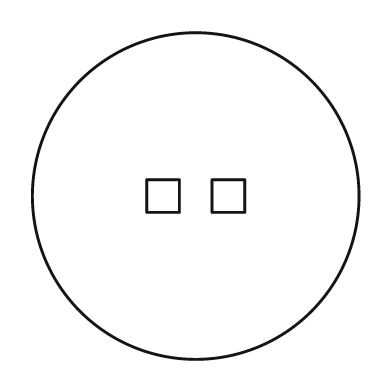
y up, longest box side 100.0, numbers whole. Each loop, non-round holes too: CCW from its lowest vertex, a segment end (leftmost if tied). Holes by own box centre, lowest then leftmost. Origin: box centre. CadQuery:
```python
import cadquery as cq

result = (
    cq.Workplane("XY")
    .moveTo(0.0, 0.0)
    .circle(50.0)
    .moveTo(-15.0, -5.0)
    .lineTo(-5.0, -5.0)
    .lineTo(-5.0, 5.0)
    .lineTo(-15.0, 5.0)
    .close()
    .moveTo(5.0, -5.0)
    .lineTo(15.0, -5.0)
    .lineTo(15.0, 5.0)
    .lineTo(5.0, 5.0)
    .close()
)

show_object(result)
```